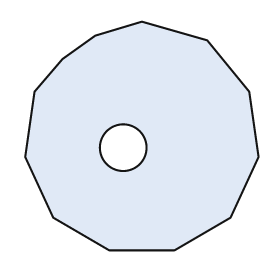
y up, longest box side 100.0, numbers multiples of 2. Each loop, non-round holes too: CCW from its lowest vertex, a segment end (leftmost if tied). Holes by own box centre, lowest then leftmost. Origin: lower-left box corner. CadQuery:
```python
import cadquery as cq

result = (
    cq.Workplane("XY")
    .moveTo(36.0, 0.0)
    .lineTo(64.0, 0.0)
    .lineTo(88.0, 14.0)
    .lineTo(100.0, 40.0)
    .lineTo(96.0, 68.0)
    .lineTo(78.0, 90.0)
    .lineTo(50.0, 98.0)
    .lineTo(30.0, 92.0)
    .lineTo(16.0, 82.0)
    .lineTo(4.0, 68.0)
    .lineTo(0.0, 40.0)
    .lineTo(12.0, 14.0)
    .close()
    .moveTo(42.0, 44.0)
    .circle(10.0)
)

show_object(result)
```